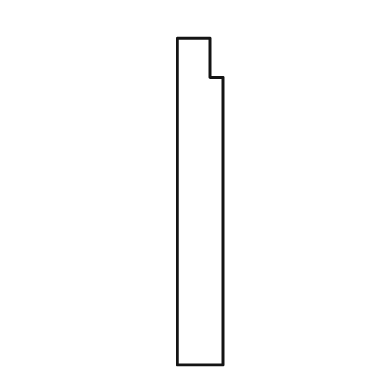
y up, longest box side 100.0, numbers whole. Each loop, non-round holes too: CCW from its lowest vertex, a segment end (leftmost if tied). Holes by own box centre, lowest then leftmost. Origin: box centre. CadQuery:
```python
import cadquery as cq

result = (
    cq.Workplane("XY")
    .moveTo(-7.0, -50.0)
    .lineTo(7.0, -50.0)
    .lineTo(7.0, 38.0)
    .lineTo(3.0, 38.0)
    .lineTo(3.0, 50.0)
    .lineTo(-7.0, 50.0)
    .close()
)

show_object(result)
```